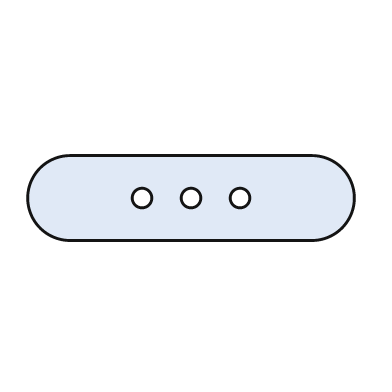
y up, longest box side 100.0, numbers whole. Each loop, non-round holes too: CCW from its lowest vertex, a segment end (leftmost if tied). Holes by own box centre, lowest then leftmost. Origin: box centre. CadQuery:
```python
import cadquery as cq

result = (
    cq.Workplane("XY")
    .moveTo(-37.0, -13.0)
    .lineTo(37.0, -13.0)
    .threePointArc((50.0, 0.0), (37.0, 13.0))
    .lineTo(-37.0, 13.0)
    .threePointArc((-50.0, 0.0), (-37.0, -13.0))
    .close()
    .moveTo(-15.0, 0.0)
    .circle(3.0)
    .moveTo(0.0, 0.0)
    .circle(3.0)
    .moveTo(15.0, 0.0)
    .circle(3.0)
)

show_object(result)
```